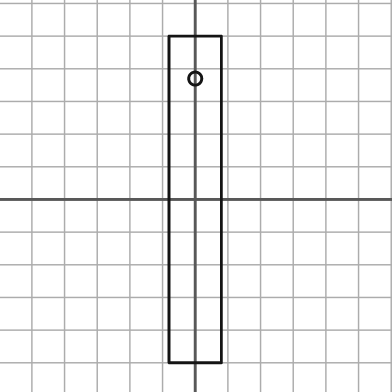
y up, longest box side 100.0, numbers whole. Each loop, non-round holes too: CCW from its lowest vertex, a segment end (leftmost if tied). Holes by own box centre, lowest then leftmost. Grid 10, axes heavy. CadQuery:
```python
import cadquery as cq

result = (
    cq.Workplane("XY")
    .moveTo(-8.0, -50.0)
    .lineTo(8.0, -50.0)
    .lineTo(8.0, 50.0)
    .lineTo(-8.0, 50.0)
    .close()
    .moveTo(0.0, 37.0)
    .circle(2.0)
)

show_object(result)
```